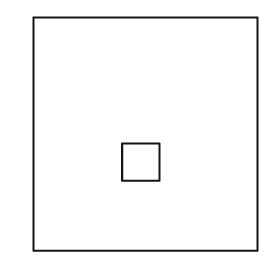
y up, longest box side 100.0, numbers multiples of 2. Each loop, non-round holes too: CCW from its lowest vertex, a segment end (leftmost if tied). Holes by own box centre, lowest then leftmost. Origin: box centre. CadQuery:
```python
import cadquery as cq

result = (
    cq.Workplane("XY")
    .moveTo(-48.0, -50.0)
    .lineTo(48.0, -50.0)
    .lineTo(48.0, 50.0)
    .lineTo(-48.0, 50.0)
    .close()
    .moveTo(-10.0, -20.0)
    .lineTo(6.0, -20.0)
    .lineTo(6.0, -4.0)
    .lineTo(-10.0, -4.0)
    .close()
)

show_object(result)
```